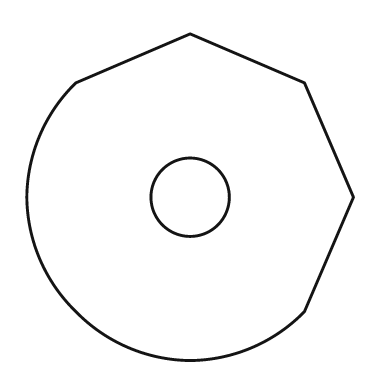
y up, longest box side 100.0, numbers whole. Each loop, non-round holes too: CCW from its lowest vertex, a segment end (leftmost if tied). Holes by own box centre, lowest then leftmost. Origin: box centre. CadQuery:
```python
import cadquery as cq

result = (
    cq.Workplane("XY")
    .moveTo(0.0, -50.0)
    .threePointArc((19.0, -46.0), (35.0, -35.0))
    .lineTo(50.0, 0.0)
    .lineTo(35.0, 35.0)
    .lineTo(0.0, 50.0)
    .lineTo(-35.0, 35.0)
    .threePointArc((-46.0, 19.0), (-50.0, 0.0))
    .threePointArc((-46.0, -19.0), (-35.0, -35.0))
    .threePointArc((-19.0, -46.0), (0.0, -50.0))
    .close()
    .moveTo(0.0, 0.0)
    .circle(12.0)
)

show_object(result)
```